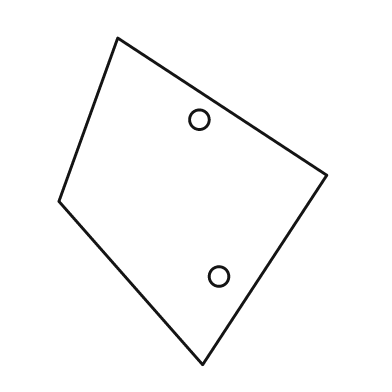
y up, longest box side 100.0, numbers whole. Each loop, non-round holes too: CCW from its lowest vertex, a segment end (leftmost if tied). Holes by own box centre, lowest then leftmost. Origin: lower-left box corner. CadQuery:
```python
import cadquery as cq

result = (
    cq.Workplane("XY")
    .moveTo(44.0, 0.0)
    .lineTo(82.0, 58.0)
    .lineTo(18.0, 100.0)
    .lineTo(0.0, 50.0)
    .close()
    .moveTo(49.0, 27.0)
    .circle(3.0)
    .moveTo(43.0, 75.0)
    .circle(3.0)
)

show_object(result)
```